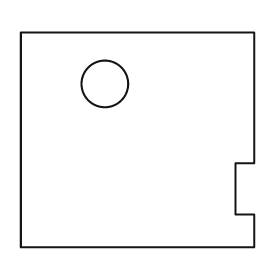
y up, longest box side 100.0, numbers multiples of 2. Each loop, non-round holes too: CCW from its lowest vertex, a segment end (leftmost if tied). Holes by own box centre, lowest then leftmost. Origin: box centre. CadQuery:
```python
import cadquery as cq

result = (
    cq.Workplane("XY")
    .moveTo(-50.0, -46.0)
    .lineTo(50.0, -46.0)
    .lineTo(50.0, -32.0)
    .lineTo(42.0, -32.0)
    .lineTo(42.0, -10.0)
    .lineTo(50.0, -10.0)
    .lineTo(50.0, 46.0)
    .lineTo(-50.0, 46.0)
    .close()
    .moveTo(-14.0, 24.0)
    .circle(10.0)
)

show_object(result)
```